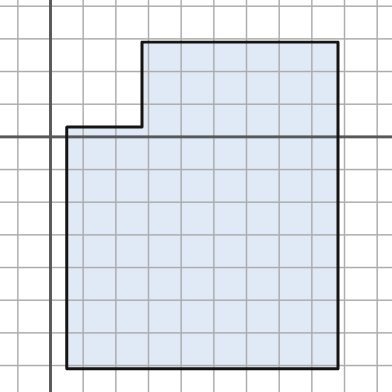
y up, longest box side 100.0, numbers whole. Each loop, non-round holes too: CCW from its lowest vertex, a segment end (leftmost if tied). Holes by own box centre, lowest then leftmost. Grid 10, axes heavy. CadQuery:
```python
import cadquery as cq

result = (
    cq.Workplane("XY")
    .moveTo(5.0, -71.0)
    .lineTo(88.0, -71.0)
    .lineTo(88.0, 29.0)
    .lineTo(28.0, 29.0)
    .lineTo(28.0, 3.0)
    .lineTo(5.0, 3.0)
    .close()
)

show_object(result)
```